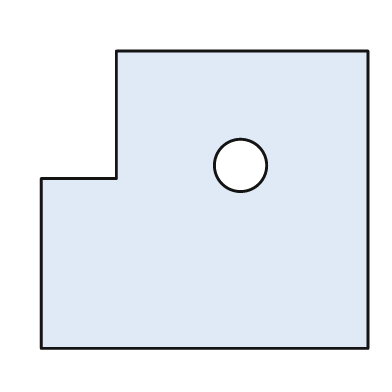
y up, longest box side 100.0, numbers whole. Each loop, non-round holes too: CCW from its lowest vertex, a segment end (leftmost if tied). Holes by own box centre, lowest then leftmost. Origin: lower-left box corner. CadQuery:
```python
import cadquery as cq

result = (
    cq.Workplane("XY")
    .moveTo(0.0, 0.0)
    .lineTo(100.0, 0.0)
    .lineTo(100.0, 91.0)
    .lineTo(23.0, 91.0)
    .lineTo(23.0, 52.0)
    .lineTo(0.0, 52.0)
    .close()
    .moveTo(61.0, 56.0)
    .circle(8.0)
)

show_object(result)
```